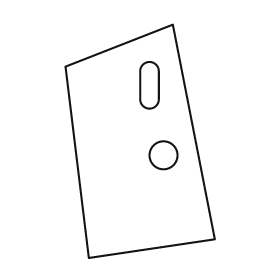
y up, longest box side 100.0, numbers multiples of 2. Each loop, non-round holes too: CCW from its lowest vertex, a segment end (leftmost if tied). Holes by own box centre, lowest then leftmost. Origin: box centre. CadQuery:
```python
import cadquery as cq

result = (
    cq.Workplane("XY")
    .moveTo(-22.0, -50.0)
    .lineTo(32.0, -42.0)
    .lineTo(14.0, 50.0)
    .lineTo(-32.0, 32.0)
    .close()
    .moveTo(10.0, -6.0)
    .circle(6.0)
    .moveTo(0.0, 18.0)
    .threePointArc((4.0, 14.0), (8.0, 18.0))
    .lineTo(8.0, 30.0)
    .threePointArc((4.0, 34.0), (0.0, 30.0))
    .close()
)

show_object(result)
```